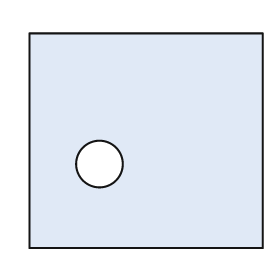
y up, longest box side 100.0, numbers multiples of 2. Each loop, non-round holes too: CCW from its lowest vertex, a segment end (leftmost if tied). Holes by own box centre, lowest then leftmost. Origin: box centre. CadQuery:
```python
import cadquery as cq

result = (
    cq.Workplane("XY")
    .moveTo(-50.0, -46.0)
    .lineTo(50.0, -46.0)
    .lineTo(50.0, 46.0)
    .lineTo(-50.0, 46.0)
    .close()
    .moveTo(-20.0, -10.0)
    .circle(10.0)
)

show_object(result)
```